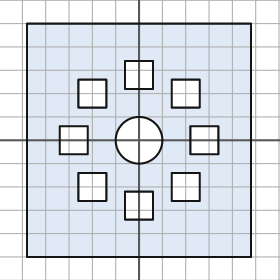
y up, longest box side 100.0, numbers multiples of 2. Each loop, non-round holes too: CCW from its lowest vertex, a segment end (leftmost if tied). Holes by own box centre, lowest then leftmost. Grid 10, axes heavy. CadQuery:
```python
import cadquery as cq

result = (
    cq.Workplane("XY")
    .moveTo(-48.0, -50.0)
    .lineTo(48.0, -50.0)
    .lineTo(48.0, 50.0)
    .lineTo(-48.0, 50.0)
    .close()
    .moveTo(-6.0, -34.0)
    .lineTo(6.0, -34.0)
    .lineTo(6.0, -22.0)
    .lineTo(-6.0, -22.0)
    .close()
    .moveTo(-26.0, -26.0)
    .lineTo(-14.0, -26.0)
    .lineTo(-14.0, -14.0)
    .lineTo(-26.0, -14.0)
    .close()
    .moveTo(14.0, -26.0)
    .lineTo(26.0, -26.0)
    .lineTo(26.0, -14.0)
    .lineTo(14.0, -14.0)
    .close()
    .moveTo(-34.0, -6.0)
    .lineTo(-22.0, -6.0)
    .lineTo(-22.0, 6.0)
    .lineTo(-34.0, 6.0)
    .close()
    .moveTo(0.0, 0.0)
    .circle(10.0)
    .moveTo(22.0, -6.0)
    .lineTo(34.0, -6.0)
    .lineTo(34.0, 6.0)
    .lineTo(22.0, 6.0)
    .close()
    .moveTo(-26.0, 14.0)
    .lineTo(-14.0, 14.0)
    .lineTo(-14.0, 26.0)
    .lineTo(-26.0, 26.0)
    .close()
    .moveTo(14.0, 14.0)
    .lineTo(26.0, 14.0)
    .lineTo(26.0, 26.0)
    .lineTo(14.0, 26.0)
    .close()
    .moveTo(-6.0, 22.0)
    .lineTo(6.0, 22.0)
    .lineTo(6.0, 34.0)
    .lineTo(-6.0, 34.0)
    .close()
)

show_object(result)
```